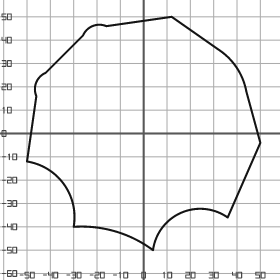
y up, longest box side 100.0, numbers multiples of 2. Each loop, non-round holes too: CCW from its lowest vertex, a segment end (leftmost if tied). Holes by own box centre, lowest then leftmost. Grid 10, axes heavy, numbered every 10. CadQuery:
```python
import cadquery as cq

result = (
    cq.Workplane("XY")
    .moveTo(4.0, -50.0)
    .threePointArc((16.0, -34.0), (36.0, -36.0))
    .lineTo(50.0, -4.0)
    .lineTo(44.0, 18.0)
    .threePointArc((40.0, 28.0), (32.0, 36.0))
    .lineTo(12.0, 50.0)
    .lineTo(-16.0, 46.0)
    .threePointArc((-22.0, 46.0), (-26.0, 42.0))
    .lineTo(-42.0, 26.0)
    .threePointArc((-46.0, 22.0), (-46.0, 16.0))
    .lineTo(-50.0, -12.0)
    .threePointArc((-34.0, -22.0), (-30.0, -40.0))
    .threePointArc((-12.0, -42.0), (4.0, -50.0))
    .close()
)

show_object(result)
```